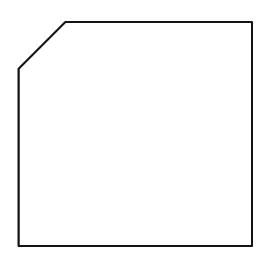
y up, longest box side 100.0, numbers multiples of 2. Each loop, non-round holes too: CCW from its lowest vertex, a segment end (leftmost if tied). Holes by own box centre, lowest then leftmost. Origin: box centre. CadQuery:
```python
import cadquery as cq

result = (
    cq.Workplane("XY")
    .moveTo(-50.0, -48.0)
    .lineTo(50.0, -48.0)
    .lineTo(50.0, 48.0)
    .lineTo(-30.0, 48.0)
    .lineTo(-50.0, 28.0)
    .close()
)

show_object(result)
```